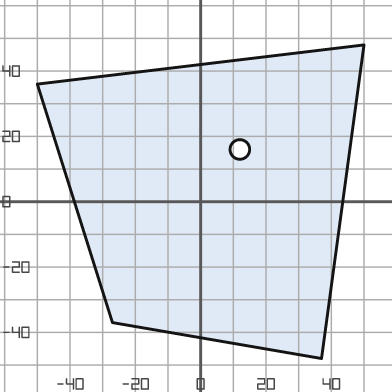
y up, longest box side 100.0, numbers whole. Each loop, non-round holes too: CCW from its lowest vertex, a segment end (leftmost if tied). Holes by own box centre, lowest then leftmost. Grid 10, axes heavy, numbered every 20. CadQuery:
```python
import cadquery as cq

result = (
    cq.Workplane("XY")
    .moveTo(37.0, -48.0)
    .lineTo(50.0, 48.0)
    .lineTo(-50.0, 36.0)
    .lineTo(-27.0, -37.0)
    .close()
    .moveTo(12.0, 16.0)
    .circle(3.0)
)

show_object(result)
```